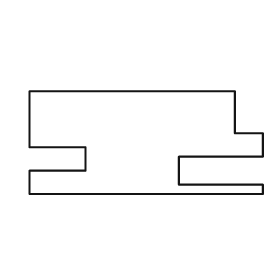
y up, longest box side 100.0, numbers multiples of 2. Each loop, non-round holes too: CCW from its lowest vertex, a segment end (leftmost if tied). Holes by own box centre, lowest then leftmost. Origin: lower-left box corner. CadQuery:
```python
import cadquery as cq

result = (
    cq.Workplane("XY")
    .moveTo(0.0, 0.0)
    .lineTo(100.0, 0.0)
    .lineTo(100.0, 4.0)
    .lineTo(64.0, 4.0)
    .lineTo(64.0, 16.0)
    .lineTo(100.0, 16.0)
    .lineTo(100.0, 26.0)
    .lineTo(88.0, 26.0)
    .lineTo(88.0, 44.0)
    .lineTo(0.0, 44.0)
    .lineTo(0.0, 20.0)
    .lineTo(24.0, 20.0)
    .lineTo(24.0, 10.0)
    .lineTo(0.0, 10.0)
    .close()
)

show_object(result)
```